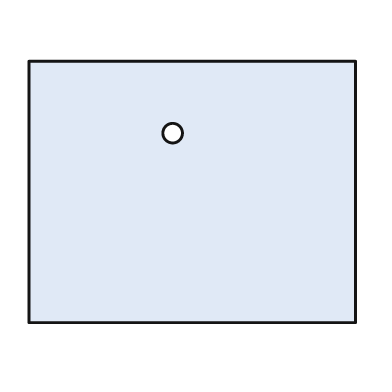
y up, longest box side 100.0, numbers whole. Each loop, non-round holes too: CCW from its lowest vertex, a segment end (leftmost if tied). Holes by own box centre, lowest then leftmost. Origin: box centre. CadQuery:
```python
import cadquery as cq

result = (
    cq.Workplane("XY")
    .moveTo(-50.0, -40.0)
    .lineTo(50.0, -40.0)
    .lineTo(50.0, 40.0)
    .lineTo(-50.0, 40.0)
    .close()
    .moveTo(-6.0, 18.0)
    .circle(3.0)
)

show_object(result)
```